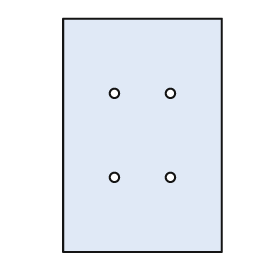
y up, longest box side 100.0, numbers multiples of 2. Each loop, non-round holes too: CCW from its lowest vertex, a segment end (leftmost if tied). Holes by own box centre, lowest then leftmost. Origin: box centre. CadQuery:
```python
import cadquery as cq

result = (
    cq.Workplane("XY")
    .moveTo(-34.0, -50.0)
    .lineTo(34.0, -50.0)
    .lineTo(34.0, 50.0)
    .lineTo(-34.0, 50.0)
    .close()
    .moveTo(-12.0, -18.0)
    .circle(2.0)
    .moveTo(12.0, -18.0)
    .circle(2.0)
    .moveTo(-12.0, 18.0)
    .circle(2.0)
    .moveTo(12.0, 18.0)
    .circle(2.0)
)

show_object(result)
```